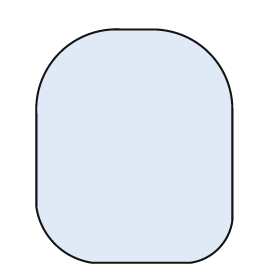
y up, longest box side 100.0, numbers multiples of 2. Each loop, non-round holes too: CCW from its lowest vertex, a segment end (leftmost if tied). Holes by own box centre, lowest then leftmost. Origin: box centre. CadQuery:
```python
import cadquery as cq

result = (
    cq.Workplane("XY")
    .moveTo(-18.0, -50.0)
    .lineTo(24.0, -50.0)
    .threePointArc((36.0, -44.0), (42.0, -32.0))
    .lineTo(42.0, 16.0)
    .threePointArc((32.0, 40.0), (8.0, 50.0))
    .lineTo(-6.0, 50.0)
    .threePointArc((-32.0, 40.0), (-42.0, 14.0))
    .lineTo(-42.0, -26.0)
    .threePointArc((-34.0, -42.0), (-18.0, -50.0))
    .close()
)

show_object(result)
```